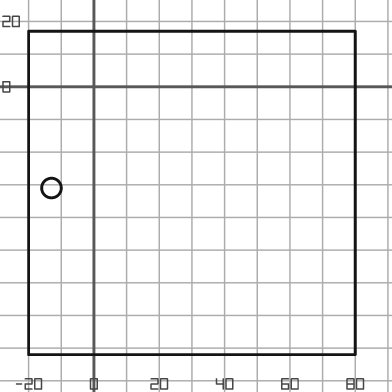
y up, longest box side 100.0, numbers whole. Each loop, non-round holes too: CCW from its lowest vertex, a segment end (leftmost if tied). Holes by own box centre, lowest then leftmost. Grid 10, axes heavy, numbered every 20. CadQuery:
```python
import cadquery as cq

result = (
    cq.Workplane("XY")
    .moveTo(-20.0, -82.0)
    .lineTo(80.0, -82.0)
    .lineTo(80.0, 17.0)
    .lineTo(-20.0, 17.0)
    .close()
    .moveTo(-13.0, -31.0)
    .circle(3.0)
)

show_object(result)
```